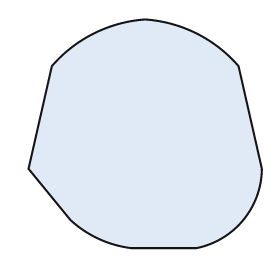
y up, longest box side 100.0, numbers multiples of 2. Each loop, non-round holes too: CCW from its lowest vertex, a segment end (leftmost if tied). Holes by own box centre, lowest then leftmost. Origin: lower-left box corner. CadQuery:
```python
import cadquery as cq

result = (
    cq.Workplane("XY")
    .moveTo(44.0, 0.0)
    .lineTo(72.0, 0.0)
    .threePointArc((92.0, 12.0), (100.0, 34.0))
    .lineTo(90.0, 78.0)
    .threePointArc((72.0, 92.0), (50.0, 98.0))
    .threePointArc((28.0, 92.0), (10.0, 78.0))
    .lineTo(0.0, 34.0)
    .lineTo(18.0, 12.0)
    .threePointArc((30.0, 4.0), (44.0, 0.0))
    .close()
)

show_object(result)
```